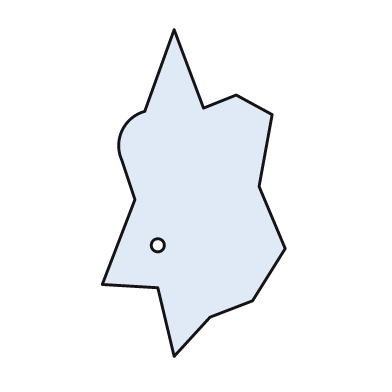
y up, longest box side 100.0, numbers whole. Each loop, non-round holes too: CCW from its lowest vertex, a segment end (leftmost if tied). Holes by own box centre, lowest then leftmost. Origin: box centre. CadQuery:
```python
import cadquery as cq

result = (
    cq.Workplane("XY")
    .moveTo(-6.0, -50.0)
    .lineTo(5.0, -38.0)
    .lineTo(18.0, -33.0)
    .lineTo(28.0, -17.0)
    .lineTo(20.0, 2.0)
    .lineTo(24.0, 24.0)
    .lineTo(13.0, 30.0)
    .lineTo(3.0, 26.0)
    .lineTo(-6.0, 50.0)
    .lineTo(-15.0, 25.0)
    .threePointArc((-22.0, 19.0), (-22.0, 10.0))
    .lineTo(-18.0, -2.0)
    .lineTo(-28.0, -28.0)
    .lineTo(-11.0, -29.0)
    .close()
    .moveTo(-11.0, -16.0)
    .circle(2.0)
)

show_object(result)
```